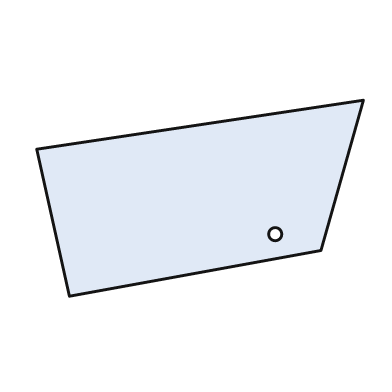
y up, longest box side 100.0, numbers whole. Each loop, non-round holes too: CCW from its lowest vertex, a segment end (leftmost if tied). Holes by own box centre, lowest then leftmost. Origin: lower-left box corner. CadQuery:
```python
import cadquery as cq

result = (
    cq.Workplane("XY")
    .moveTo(10.0, 0.0)
    .lineTo(87.0, 14.0)
    .lineTo(100.0, 60.0)
    .lineTo(0.0, 45.0)
    .close()
    .moveTo(73.0, 19.0)
    .circle(2.0)
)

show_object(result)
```